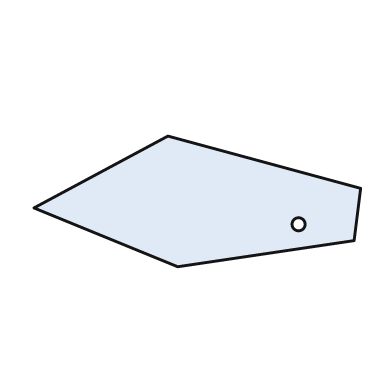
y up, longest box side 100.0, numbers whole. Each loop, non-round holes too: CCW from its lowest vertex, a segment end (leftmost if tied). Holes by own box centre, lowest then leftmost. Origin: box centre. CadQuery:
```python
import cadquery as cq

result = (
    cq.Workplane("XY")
    .moveTo(-6.0, -20.0)
    .lineTo(48.0, -12.0)
    .lineTo(50.0, 4.0)
    .lineTo(-9.0, 20.0)
    .lineTo(-50.0, -2.0)
    .close()
    .moveTo(31.0, -7.0)
    .circle(2.0)
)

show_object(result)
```